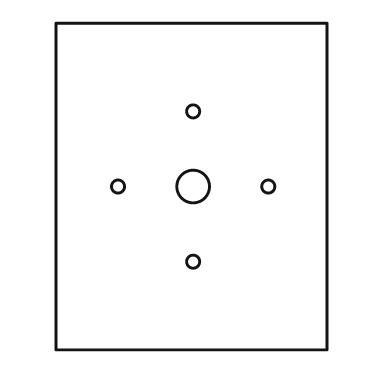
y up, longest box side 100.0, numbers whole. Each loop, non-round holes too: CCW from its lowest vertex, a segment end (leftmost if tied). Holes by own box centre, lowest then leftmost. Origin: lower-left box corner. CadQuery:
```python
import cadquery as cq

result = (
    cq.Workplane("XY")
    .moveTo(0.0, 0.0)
    .lineTo(83.0, 0.0)
    .lineTo(83.0, 100.0)
    .lineTo(0.0, 100.0)
    .close()
    .moveTo(42.0, 27.0)
    .circle(2.0)
    .moveTo(19.0, 50.0)
    .circle(2.0)
    .moveTo(42.0, 50.0)
    .circle(5.0)
    .moveTo(65.0, 50.0)
    .circle(2.0)
    .moveTo(42.0, 73.0)
    .circle(2.0)
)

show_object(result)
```